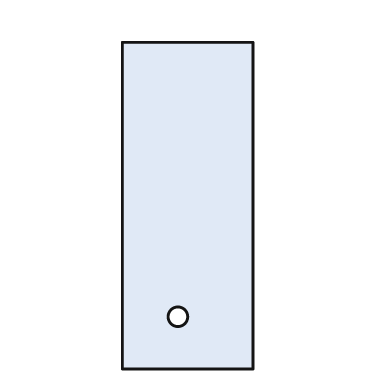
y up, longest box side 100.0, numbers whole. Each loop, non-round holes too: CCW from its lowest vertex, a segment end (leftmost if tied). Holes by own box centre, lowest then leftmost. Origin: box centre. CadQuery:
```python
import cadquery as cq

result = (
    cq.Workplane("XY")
    .moveTo(-20.0, -50.0)
    .lineTo(20.0, -50.0)
    .lineTo(20.0, 50.0)
    .lineTo(-20.0, 50.0)
    .close()
    .moveTo(-3.0, -34.0)
    .circle(3.0)
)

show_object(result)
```